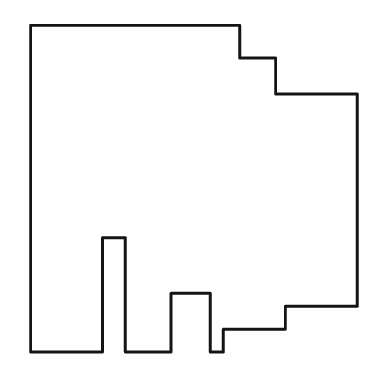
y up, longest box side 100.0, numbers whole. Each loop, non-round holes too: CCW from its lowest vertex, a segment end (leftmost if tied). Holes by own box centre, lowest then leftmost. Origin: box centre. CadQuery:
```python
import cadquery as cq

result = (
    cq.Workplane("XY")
    .moveTo(-50.0, -50.0)
    .lineTo(-28.0, -50.0)
    .lineTo(-28.0, -15.0)
    .lineTo(-21.0, -15.0)
    .lineTo(-21.0, -50.0)
    .lineTo(-7.0, -50.0)
    .lineTo(-7.0, -32.0)
    .lineTo(5.0, -32.0)
    .lineTo(5.0, -50.0)
    .lineTo(9.0, -50.0)
    .lineTo(9.0, -43.0)
    .lineTo(28.0, -43.0)
    .lineTo(28.0, -36.0)
    .lineTo(50.0, -36.0)
    .lineTo(50.0, 29.0)
    .lineTo(25.0, 29.0)
    .lineTo(25.0, 40.0)
    .lineTo(14.0, 40.0)
    .lineTo(14.0, 50.0)
    .lineTo(-50.0, 50.0)
    .close()
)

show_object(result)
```